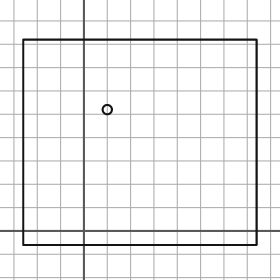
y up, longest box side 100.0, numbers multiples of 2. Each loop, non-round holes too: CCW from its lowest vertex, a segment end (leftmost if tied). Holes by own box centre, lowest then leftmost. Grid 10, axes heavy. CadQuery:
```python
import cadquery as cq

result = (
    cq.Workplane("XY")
    .moveTo(-26.0, -6.0)
    .lineTo(74.0, -6.0)
    .lineTo(74.0, 82.0)
    .lineTo(-26.0, 82.0)
    .close()
    .moveTo(10.0, 52.0)
    .circle(2.0)
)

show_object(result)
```